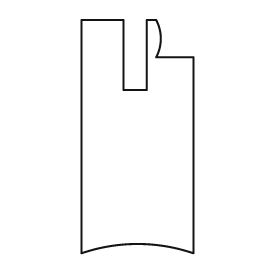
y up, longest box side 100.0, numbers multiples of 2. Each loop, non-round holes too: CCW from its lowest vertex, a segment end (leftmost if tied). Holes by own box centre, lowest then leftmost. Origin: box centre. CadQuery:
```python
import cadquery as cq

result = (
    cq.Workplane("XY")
    .moveTo(-24.0, -50.0)
    .threePointArc((0.0, -46.0), (24.0, -50.0))
    .lineTo(24.0, 34.0)
    .lineTo(8.0, 34.0)
    .threePointArc((10.0, 42.0), (8.0, 50.0))
    .lineTo(4.0, 50.0)
    .lineTo(4.0, 20.0)
    .lineTo(-6.0, 20.0)
    .lineTo(-6.0, 50.0)
    .lineTo(-24.0, 50.0)
    .close()
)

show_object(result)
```